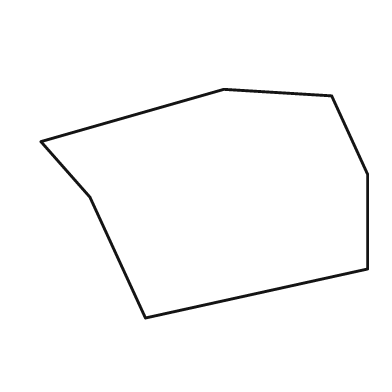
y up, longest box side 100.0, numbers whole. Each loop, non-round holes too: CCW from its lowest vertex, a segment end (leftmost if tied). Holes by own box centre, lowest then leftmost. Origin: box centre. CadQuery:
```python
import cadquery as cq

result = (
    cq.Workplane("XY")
    .moveTo(-18.0, -35.0)
    .lineTo(50.0, -20.0)
    .lineTo(50.0, 9.0)
    .lineTo(39.0, 33.0)
    .lineTo(6.0, 35.0)
    .lineTo(-50.0, 19.0)
    .lineTo(-35.0, 2.0)
    .close()
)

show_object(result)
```